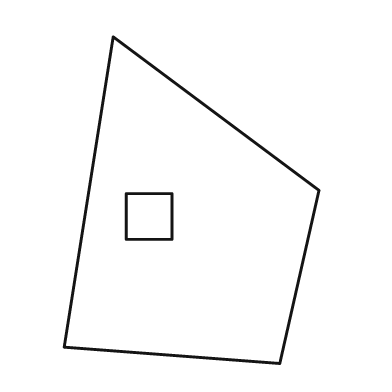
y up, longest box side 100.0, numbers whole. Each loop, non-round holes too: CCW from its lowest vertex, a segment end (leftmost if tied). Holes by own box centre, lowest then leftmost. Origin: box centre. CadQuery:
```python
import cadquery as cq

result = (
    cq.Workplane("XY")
    .moveTo(27.0, -50.0)
    .lineTo(39.0, 3.0)
    .lineTo(-24.0, 50.0)
    .lineTo(-39.0, -45.0)
    .close()
    .moveTo(-20.0, -12.0)
    .lineTo(-6.0, -12.0)
    .lineTo(-6.0, 2.0)
    .lineTo(-20.0, 2.0)
    .close()
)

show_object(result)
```